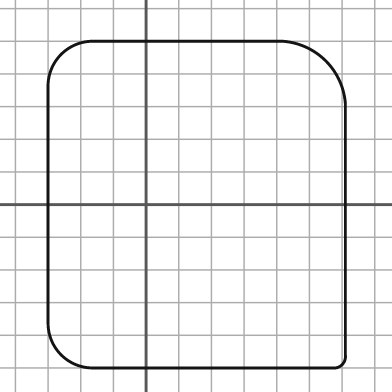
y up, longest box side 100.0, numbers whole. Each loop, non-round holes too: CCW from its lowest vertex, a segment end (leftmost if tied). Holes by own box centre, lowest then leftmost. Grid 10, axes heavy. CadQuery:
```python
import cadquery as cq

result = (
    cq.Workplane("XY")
    .moveTo(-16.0, -50.0)
    .lineTo(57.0, -50.0)
    .threePointArc((60.0, -49.0), (61.0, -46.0))
    .lineTo(61.0, 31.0)
    .threePointArc((55.0, 44.0), (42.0, 50.0))
    .lineTo(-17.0, 50.0)
    .threePointArc((-26.0, 46.0), (-30.0, 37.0))
    .lineTo(-30.0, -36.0)
    .threePointArc((-26.0, -46.0), (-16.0, -50.0))
    .close()
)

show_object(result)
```